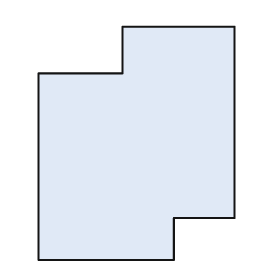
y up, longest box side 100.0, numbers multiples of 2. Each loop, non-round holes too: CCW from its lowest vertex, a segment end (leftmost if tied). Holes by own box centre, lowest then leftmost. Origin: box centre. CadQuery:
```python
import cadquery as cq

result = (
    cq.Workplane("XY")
    .moveTo(-42.0, -50.0)
    .lineTo(16.0, -50.0)
    .lineTo(16.0, -32.0)
    .lineTo(42.0, -32.0)
    .lineTo(42.0, 50.0)
    .lineTo(-6.0, 50.0)
    .lineTo(-6.0, 30.0)
    .lineTo(-42.0, 30.0)
    .close()
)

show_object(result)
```